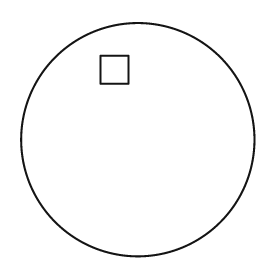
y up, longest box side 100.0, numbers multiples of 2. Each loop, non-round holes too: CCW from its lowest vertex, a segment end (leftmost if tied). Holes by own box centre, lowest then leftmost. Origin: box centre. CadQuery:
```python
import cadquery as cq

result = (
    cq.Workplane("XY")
    .moveTo(0.0, 0.0)
    .circle(50.0)
    .moveTo(-16.0, 24.0)
    .lineTo(-4.0, 24.0)
    .lineTo(-4.0, 36.0)
    .lineTo(-16.0, 36.0)
    .close()
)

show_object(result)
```